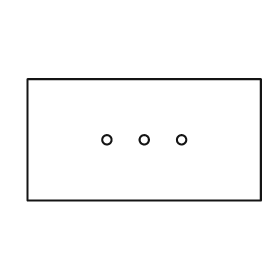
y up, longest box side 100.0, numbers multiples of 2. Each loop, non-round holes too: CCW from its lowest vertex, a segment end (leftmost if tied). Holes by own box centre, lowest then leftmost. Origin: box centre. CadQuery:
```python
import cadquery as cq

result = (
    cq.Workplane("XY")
    .moveTo(-50.0, -26.0)
    .lineTo(50.0, -26.0)
    .lineTo(50.0, 26.0)
    .lineTo(-50.0, 26.0)
    .close()
    .moveTo(-16.0, 0.0)
    .circle(2.0)
    .moveTo(0.0, 0.0)
    .circle(2.0)
    .moveTo(16.0, 0.0)
    .circle(2.0)
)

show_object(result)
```